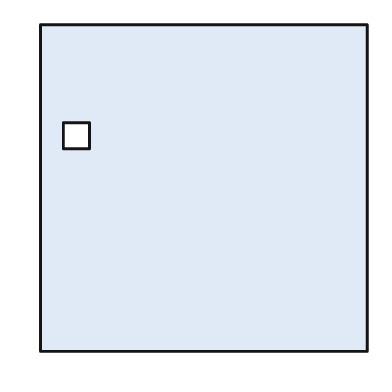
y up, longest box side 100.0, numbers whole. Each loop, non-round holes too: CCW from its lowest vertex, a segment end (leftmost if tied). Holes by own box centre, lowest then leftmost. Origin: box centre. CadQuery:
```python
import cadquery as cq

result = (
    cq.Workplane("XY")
    .moveTo(-50.0, -50.0)
    .lineTo(50.0, -50.0)
    .lineTo(50.0, 50.0)
    .lineTo(-50.0, 50.0)
    .close()
    .moveTo(-43.0, 12.0)
    .lineTo(-35.0, 12.0)
    .lineTo(-35.0, 20.0)
    .lineTo(-43.0, 20.0)
    .close()
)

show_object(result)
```